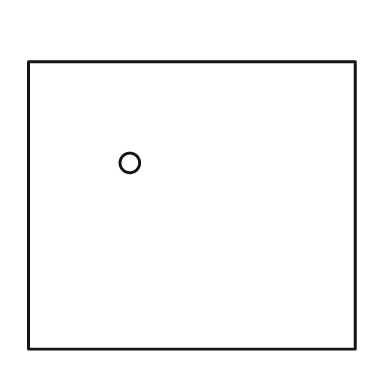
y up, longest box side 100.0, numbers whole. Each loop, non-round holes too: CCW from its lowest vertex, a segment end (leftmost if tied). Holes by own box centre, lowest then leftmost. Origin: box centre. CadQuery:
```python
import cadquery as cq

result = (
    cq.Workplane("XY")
    .moveTo(-50.0, -44.0)
    .lineTo(50.0, -44.0)
    .lineTo(50.0, 44.0)
    .lineTo(-50.0, 44.0)
    .close()
    .moveTo(-19.0, 13.0)
    .circle(3.0)
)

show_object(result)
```